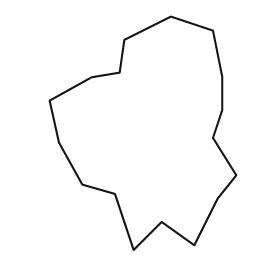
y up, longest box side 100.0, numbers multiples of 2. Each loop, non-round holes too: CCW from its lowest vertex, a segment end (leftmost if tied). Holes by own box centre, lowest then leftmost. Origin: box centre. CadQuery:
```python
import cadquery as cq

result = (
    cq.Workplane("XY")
    .moveTo(-4.0, -50.0)
    .lineTo(8.0, -38.0)
    .lineTo(22.0, -48.0)
    .lineTo(32.0, -28.0)
    .lineTo(40.0, -18.0)
    .lineTo(30.0, -2.0)
    .lineTo(34.0, 10.0)
    .lineTo(34.0, 24.0)
    .lineTo(30.0, 44.0)
    .lineTo(12.0, 50.0)
    .lineTo(-8.0, 40.0)
    .lineTo(-10.0, 26.0)
    .lineTo(-22.0, 24.0)
    .lineTo(-40.0, 14.0)
    .lineTo(-36.0, -4.0)
    .lineTo(-26.0, -22.0)
    .lineTo(-12.0, -26.0)
    .close()
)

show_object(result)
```